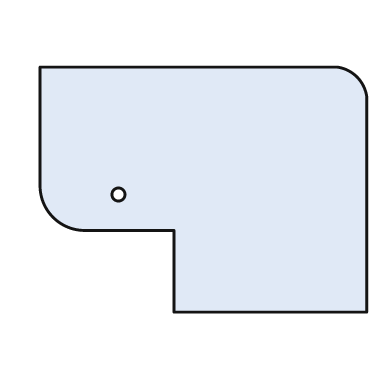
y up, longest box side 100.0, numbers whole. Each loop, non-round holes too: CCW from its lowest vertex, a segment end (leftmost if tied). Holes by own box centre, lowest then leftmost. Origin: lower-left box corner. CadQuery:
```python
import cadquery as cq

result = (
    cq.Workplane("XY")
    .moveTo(41.0, 0.0)
    .lineTo(100.0, 0.0)
    .lineTo(100.0, 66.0)
    .threePointArc((97.0, 72.0), (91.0, 75.0))
    .lineTo(0.0, 75.0)
    .lineTo(0.0, 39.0)
    .threePointArc((4.0, 29.0), (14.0, 25.0))
    .lineTo(41.0, 25.0)
    .close()
    .moveTo(24.0, 36.0)
    .circle(2.0)
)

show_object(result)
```